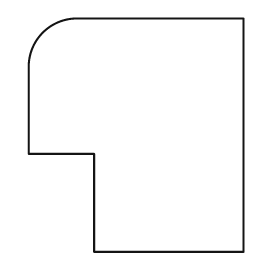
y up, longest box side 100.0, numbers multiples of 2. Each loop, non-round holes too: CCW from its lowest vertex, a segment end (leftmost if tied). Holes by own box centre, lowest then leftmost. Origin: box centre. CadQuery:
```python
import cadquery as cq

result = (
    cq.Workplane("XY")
    .moveTo(-18.0, -50.0)
    .lineTo(46.0, -50.0)
    .lineTo(46.0, 50.0)
    .lineTo(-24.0, 50.0)
    .threePointArc((-40.0, 44.0), (-46.0, 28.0))
    .lineTo(-46.0, -8.0)
    .lineTo(-18.0, -8.0)
    .close()
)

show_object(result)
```